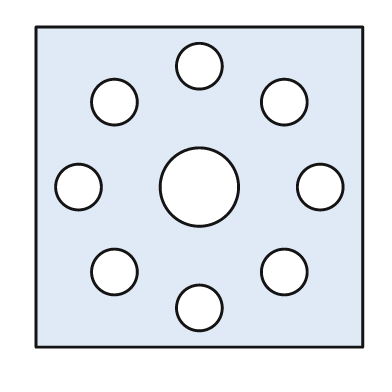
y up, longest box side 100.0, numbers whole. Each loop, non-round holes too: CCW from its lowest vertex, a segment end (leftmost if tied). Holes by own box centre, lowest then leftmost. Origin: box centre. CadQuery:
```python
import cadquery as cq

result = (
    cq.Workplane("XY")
    .moveTo(-50.0, -49.0)
    .lineTo(50.0, -49.0)
    .lineTo(50.0, 49.0)
    .lineTo(-50.0, 49.0)
    .close()
    .moveTo(0.0, -37.0)
    .circle(7.0)
    .moveTo(-26.0, -26.0)
    .circle(7.0)
    .moveTo(26.0, -26.0)
    .circle(7.0)
    .moveTo(-37.0, 0.0)
    .circle(7.0)
    .moveTo(0.0, 0.0)
    .circle(12.0)
    .moveTo(37.0, 0.0)
    .circle(7.0)
    .moveTo(-26.0, 26.0)
    .circle(7.0)
    .moveTo(26.0, 26.0)
    .circle(7.0)
    .moveTo(0.0, 37.0)
    .circle(7.0)
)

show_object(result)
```